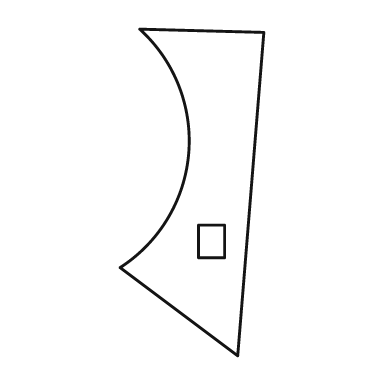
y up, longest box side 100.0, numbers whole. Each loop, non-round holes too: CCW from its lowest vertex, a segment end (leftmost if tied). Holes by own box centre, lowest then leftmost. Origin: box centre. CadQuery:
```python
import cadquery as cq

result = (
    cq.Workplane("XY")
    .moveTo(14.0, -50.0)
    .lineTo(22.0, 49.0)
    .lineTo(-16.0, 50.0)
    .threePointArc((-1.0, 12.0), (-22.0, -23.0))
    .close()
    .moveTo(2.0, -20.0)
    .lineTo(10.0, -20.0)
    .lineTo(10.0, -10.0)
    .lineTo(2.0, -10.0)
    .close()
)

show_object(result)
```